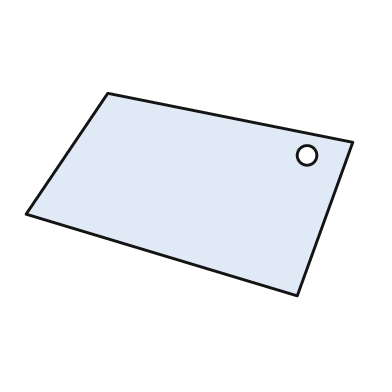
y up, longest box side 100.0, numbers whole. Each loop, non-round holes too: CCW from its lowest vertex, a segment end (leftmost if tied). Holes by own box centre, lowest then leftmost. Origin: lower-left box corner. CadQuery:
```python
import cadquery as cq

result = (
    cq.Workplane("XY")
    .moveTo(83.0, 0.0)
    .lineTo(100.0, 47.0)
    .lineTo(25.0, 62.0)
    .lineTo(0.0, 25.0)
    .close()
    .moveTo(86.0, 43.0)
    .circle(3.0)
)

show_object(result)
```